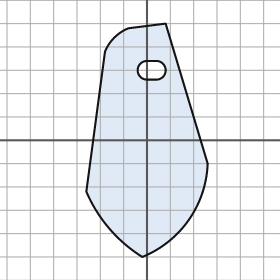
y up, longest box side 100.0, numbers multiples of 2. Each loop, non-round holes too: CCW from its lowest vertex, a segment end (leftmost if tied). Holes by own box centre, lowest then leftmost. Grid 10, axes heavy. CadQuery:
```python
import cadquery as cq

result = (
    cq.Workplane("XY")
    .moveTo(-2.0, -50.0)
    .threePointArc((18.0, -34.0), (26.0, -10.0))
    .lineTo(8.0, 50.0)
    .lineTo(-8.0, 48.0)
    .threePointArc((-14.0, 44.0), (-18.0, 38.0))
    .lineTo(-26.0, -22.0)
    .threePointArc((-16.0, -38.0), (-2.0, -50.0))
    .close()
    .moveTo(0.0, 26.0)
    .lineTo(4.0, 26.0)
    .threePointArc((8.0, 30.0), (4.0, 34.0))
    .lineTo(0.0, 34.0)
    .threePointArc((-4.0, 30.0), (0.0, 26.0))
    .close()
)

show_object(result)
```